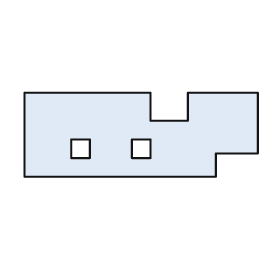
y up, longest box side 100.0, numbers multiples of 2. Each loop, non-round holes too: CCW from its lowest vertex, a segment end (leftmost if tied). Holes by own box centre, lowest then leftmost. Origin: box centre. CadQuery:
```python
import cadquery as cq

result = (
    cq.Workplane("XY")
    .moveTo(-50.0, -18.0)
    .lineTo(32.0, -18.0)
    .lineTo(32.0, -8.0)
    .lineTo(50.0, -8.0)
    .lineTo(50.0, 18.0)
    .lineTo(20.0, 18.0)
    .lineTo(20.0, 6.0)
    .lineTo(4.0, 6.0)
    .lineTo(4.0, 18.0)
    .lineTo(-50.0, 18.0)
    .close()
    .moveTo(-30.0, -10.0)
    .lineTo(-22.0, -10.0)
    .lineTo(-22.0, -2.0)
    .lineTo(-30.0, -2.0)
    .close()
    .moveTo(-4.0, -10.0)
    .lineTo(4.0, -10.0)
    .lineTo(4.0, -2.0)
    .lineTo(-4.0, -2.0)
    .close()
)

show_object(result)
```